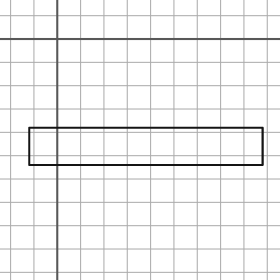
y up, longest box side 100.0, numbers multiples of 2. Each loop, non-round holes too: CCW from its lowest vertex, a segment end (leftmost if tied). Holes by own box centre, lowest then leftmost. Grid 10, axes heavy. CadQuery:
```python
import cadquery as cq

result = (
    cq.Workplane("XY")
    .moveTo(-12.0, -54.0)
    .lineTo(88.0, -54.0)
    .lineTo(88.0, -38.0)
    .lineTo(-12.0, -38.0)
    .close()
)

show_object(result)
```